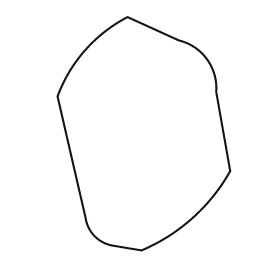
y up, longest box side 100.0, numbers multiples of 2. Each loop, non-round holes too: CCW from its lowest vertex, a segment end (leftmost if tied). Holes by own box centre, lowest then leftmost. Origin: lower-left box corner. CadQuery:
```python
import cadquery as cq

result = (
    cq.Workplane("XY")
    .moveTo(36.0, 0.0)
    .threePointArc((58.0, 14.0), (74.0, 34.0))
    .lineTo(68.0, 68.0)
    .threePointArc((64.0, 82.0), (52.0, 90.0))
    .lineTo(30.0, 100.0)
    .threePointArc((12.0, 86.0), (0.0, 66.0))
    .lineTo(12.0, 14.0)
    .threePointArc((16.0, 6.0), (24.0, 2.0))
    .close()
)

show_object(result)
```